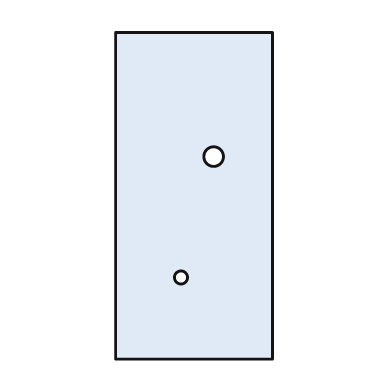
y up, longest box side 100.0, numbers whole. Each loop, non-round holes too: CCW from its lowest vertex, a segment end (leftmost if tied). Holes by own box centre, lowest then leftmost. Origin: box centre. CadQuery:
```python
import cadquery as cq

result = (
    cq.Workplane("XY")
    .moveTo(-24.0, -50.0)
    .lineTo(24.0, -50.0)
    .lineTo(24.0, 50.0)
    .lineTo(-24.0, 50.0)
    .close()
    .moveTo(-4.0, -25.0)
    .circle(2.0)
    .moveTo(6.0, 12.0)
    .circle(3.0)
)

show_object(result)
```